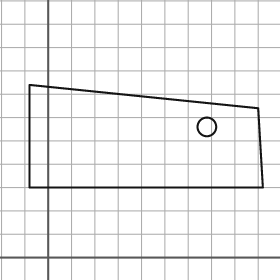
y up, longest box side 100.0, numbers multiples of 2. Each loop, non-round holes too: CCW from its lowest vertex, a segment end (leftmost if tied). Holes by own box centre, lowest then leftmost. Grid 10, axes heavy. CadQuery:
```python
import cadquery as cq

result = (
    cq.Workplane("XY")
    .moveTo(-8.0, 30.0)
    .lineTo(92.0, 30.0)
    .lineTo(90.0, 64.0)
    .lineTo(-8.0, 74.0)
    .close()
    .moveTo(68.0, 56.0)
    .circle(4.0)
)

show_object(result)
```